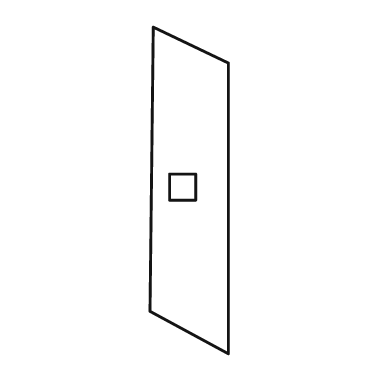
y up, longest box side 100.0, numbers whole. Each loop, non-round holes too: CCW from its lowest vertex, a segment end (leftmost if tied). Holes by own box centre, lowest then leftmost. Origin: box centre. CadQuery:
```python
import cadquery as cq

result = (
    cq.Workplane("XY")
    .moveTo(12.0, -50.0)
    .lineTo(12.0, 39.0)
    .lineTo(-11.0, 50.0)
    .lineTo(-12.0, -37.0)
    .close()
    .moveTo(-6.0, -3.0)
    .lineTo(2.0, -3.0)
    .lineTo(2.0, 5.0)
    .lineTo(-6.0, 5.0)
    .close()
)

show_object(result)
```